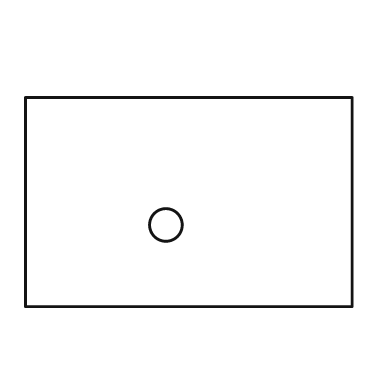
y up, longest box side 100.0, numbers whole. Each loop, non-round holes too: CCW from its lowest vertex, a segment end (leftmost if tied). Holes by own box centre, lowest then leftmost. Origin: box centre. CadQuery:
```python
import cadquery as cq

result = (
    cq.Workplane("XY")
    .moveTo(-50.0, -32.0)
    .lineTo(50.0, -32.0)
    .lineTo(50.0, 32.0)
    .lineTo(-50.0, 32.0)
    .close()
    .moveTo(-7.0, -7.0)
    .circle(5.0)
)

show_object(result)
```